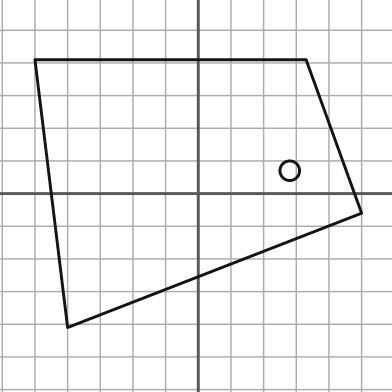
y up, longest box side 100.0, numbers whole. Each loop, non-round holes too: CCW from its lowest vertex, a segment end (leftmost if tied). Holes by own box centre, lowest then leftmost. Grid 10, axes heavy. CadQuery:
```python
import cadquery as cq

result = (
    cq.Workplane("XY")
    .moveTo(-40.0, -41.0)
    .lineTo(50.0, -6.0)
    .lineTo(33.0, 41.0)
    .lineTo(-50.0, 41.0)
    .close()
    .moveTo(28.0, 7.0)
    .circle(3.0)
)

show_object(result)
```